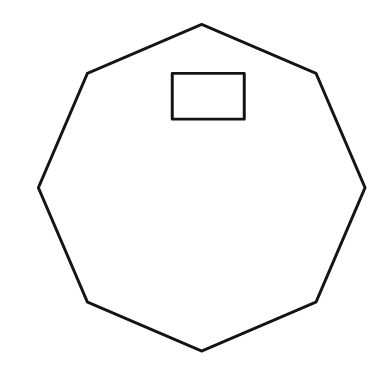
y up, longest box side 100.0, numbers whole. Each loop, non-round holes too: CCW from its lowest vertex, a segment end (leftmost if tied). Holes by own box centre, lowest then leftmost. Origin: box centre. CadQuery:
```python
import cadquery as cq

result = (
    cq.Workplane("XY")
    .moveTo(0.0, -50.0)
    .lineTo(35.0, -35.0)
    .lineTo(50.0, 0.0)
    .lineTo(35.0, 35.0)
    .lineTo(0.0, 50.0)
    .lineTo(-35.0, 35.0)
    .lineTo(-50.0, 0.0)
    .lineTo(-35.0, -35.0)
    .close()
    .moveTo(-9.0, 21.0)
    .lineTo(13.0, 21.0)
    .lineTo(13.0, 35.0)
    .lineTo(-9.0, 35.0)
    .close()
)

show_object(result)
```